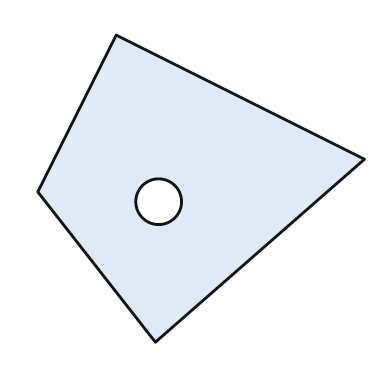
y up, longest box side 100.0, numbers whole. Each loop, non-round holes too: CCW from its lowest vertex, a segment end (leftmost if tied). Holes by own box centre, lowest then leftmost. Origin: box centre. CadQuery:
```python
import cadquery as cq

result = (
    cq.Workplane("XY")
    .moveTo(-14.0, -47.0)
    .lineTo(50.0, 9.0)
    .lineTo(-26.0, 47.0)
    .lineTo(-50.0, -1.0)
    .close()
    .moveTo(-13.0, -4.0)
    .circle(7.0)
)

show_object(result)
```